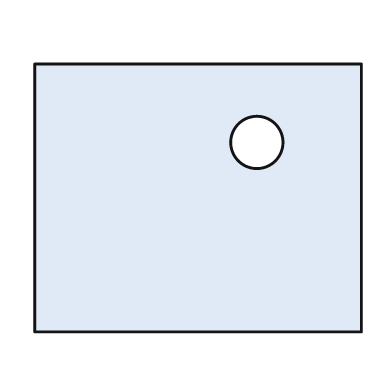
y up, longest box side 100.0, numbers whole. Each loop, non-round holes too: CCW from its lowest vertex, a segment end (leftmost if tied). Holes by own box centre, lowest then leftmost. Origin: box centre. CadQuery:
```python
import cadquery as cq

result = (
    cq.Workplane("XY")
    .moveTo(-50.0, -41.0)
    .lineTo(50.0, -41.0)
    .lineTo(50.0, 41.0)
    .lineTo(-50.0, 41.0)
    .close()
    .moveTo(18.0, 17.0)
    .circle(8.0)
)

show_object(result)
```